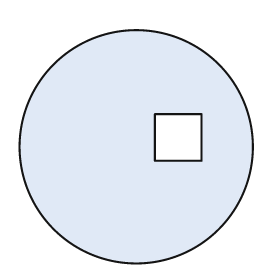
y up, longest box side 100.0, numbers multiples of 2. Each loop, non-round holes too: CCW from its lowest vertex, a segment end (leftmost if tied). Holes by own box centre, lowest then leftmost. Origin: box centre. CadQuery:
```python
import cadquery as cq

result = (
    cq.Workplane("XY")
    .moveTo(0.0, 0.0)
    .circle(50.0)
    .moveTo(8.0, -6.0)
    .lineTo(28.0, -6.0)
    .lineTo(28.0, 14.0)
    .lineTo(8.0, 14.0)
    .close()
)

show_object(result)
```